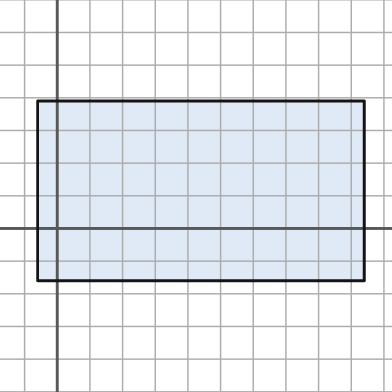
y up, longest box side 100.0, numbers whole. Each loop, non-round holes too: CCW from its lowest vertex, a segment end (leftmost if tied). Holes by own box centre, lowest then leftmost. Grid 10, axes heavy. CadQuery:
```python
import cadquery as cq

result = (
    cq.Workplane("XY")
    .moveTo(-6.0, -16.0)
    .lineTo(94.0, -16.0)
    .lineTo(94.0, 39.0)
    .lineTo(-6.0, 39.0)
    .close()
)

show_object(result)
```